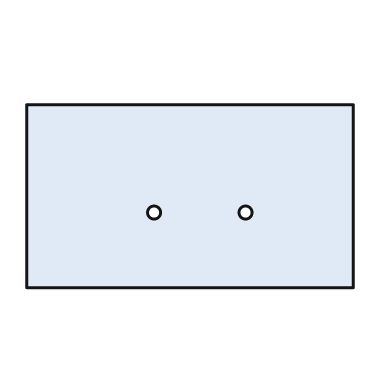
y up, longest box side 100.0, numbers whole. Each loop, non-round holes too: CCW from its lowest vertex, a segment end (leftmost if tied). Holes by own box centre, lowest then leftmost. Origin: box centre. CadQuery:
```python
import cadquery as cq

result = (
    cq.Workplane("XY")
    .moveTo(-50.0, -28.0)
    .lineTo(50.0, -28.0)
    .lineTo(50.0, 28.0)
    .lineTo(-50.0, 28.0)
    .close()
    .moveTo(-11.0, -5.0)
    .circle(2.0)
    .moveTo(17.0, -5.0)
    .circle(2.0)
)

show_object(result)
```